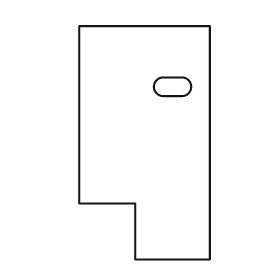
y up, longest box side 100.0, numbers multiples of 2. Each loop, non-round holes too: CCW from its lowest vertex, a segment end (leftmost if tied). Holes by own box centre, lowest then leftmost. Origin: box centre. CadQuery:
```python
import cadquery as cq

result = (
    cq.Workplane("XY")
    .moveTo(-4.0, -50.0)
    .lineTo(28.0, -50.0)
    .lineTo(28.0, 50.0)
    .lineTo(-28.0, 50.0)
    .lineTo(-28.0, -26.0)
    .lineTo(-4.0, -26.0)
    .close()
    .moveTo(8.0, 20.0)
    .lineTo(16.0, 20.0)
    .threePointArc((20.0, 24.0), (16.0, 28.0))
    .lineTo(8.0, 28.0)
    .threePointArc((4.0, 24.0), (8.0, 20.0))
    .close()
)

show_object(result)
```